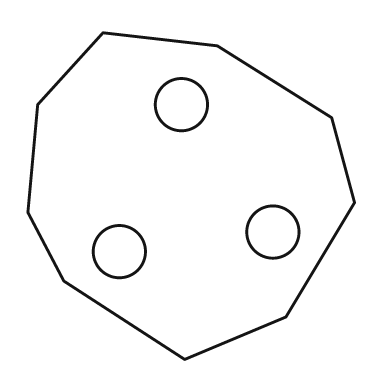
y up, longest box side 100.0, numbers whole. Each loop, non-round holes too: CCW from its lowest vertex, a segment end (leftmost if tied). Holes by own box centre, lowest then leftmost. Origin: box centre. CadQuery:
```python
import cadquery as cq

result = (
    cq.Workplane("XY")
    .moveTo(-2.0, -50.0)
    .lineTo(29.0, -37.0)
    .lineTo(50.0, -2.0)
    .lineTo(43.0, 24.0)
    .lineTo(8.0, 46.0)
    .lineTo(-27.0, 50.0)
    .lineTo(-47.0, 28.0)
    .lineTo(-50.0, -5.0)
    .lineTo(-39.0, -26.0)
    .close()
    .moveTo(-22.0, -17.0)
    .circle(8.0)
    .moveTo(25.0, -11.0)
    .circle(8.0)
    .moveTo(-3.0, 28.0)
    .circle(8.0)
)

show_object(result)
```